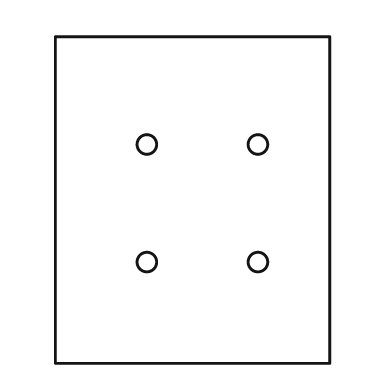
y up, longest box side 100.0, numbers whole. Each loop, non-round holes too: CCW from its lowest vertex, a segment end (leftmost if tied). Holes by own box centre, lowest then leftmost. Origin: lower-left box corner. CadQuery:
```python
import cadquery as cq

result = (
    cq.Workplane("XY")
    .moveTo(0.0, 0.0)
    .lineTo(84.0, 0.0)
    .lineTo(84.0, 100.0)
    .lineTo(0.0, 100.0)
    .close()
    .moveTo(28.0, 31.0)
    .circle(3.0)
    .moveTo(62.0, 31.0)
    .circle(3.0)
    .moveTo(28.0, 67.0)
    .circle(3.0)
    .moveTo(62.0, 67.0)
    .circle(3.0)
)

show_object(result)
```